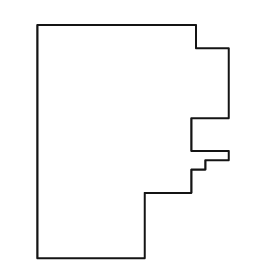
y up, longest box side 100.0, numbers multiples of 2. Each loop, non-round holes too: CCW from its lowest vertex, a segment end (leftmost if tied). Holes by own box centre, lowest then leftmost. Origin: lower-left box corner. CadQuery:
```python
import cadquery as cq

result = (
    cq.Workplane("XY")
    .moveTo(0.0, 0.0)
    .lineTo(46.0, 0.0)
    .lineTo(46.0, 28.0)
    .lineTo(66.0, 28.0)
    .lineTo(66.0, 38.0)
    .lineTo(72.0, 38.0)
    .lineTo(72.0, 42.0)
    .lineTo(82.0, 42.0)
    .lineTo(82.0, 46.0)
    .lineTo(66.0, 46.0)
    .lineTo(66.0, 60.0)
    .lineTo(82.0, 60.0)
    .lineTo(82.0, 90.0)
    .lineTo(68.0, 90.0)
    .lineTo(68.0, 100.0)
    .lineTo(0.0, 100.0)
    .close()
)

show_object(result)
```